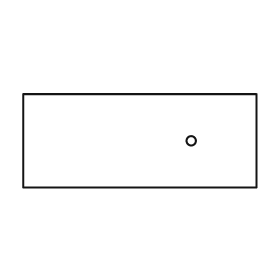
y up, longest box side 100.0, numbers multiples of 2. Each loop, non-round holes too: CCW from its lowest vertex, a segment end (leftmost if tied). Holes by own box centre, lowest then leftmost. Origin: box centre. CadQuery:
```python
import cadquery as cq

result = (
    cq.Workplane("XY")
    .moveTo(-50.0, -20.0)
    .lineTo(50.0, -20.0)
    .lineTo(50.0, 20.0)
    .lineTo(-50.0, 20.0)
    .close()
    .moveTo(22.0, 0.0)
    .circle(2.0)
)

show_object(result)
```